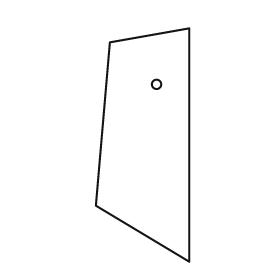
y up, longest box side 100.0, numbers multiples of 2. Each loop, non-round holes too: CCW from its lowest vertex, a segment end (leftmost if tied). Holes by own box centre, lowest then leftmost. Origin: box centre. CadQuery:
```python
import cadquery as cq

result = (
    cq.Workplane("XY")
    .moveTo(20.0, -50.0)
    .lineTo(20.0, 50.0)
    .lineTo(-14.0, 44.0)
    .lineTo(-20.0, -26.0)
    .close()
    .moveTo(6.0, 26.0)
    .circle(2.0)
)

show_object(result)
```